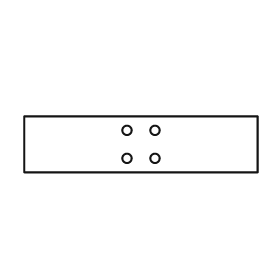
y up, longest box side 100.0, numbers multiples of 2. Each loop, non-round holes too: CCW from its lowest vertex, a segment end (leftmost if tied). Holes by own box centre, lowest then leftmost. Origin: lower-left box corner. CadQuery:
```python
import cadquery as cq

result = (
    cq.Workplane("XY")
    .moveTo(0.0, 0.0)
    .lineTo(100.0, 0.0)
    .lineTo(100.0, 24.0)
    .lineTo(0.0, 24.0)
    .close()
    .moveTo(44.0, 6.0)
    .circle(2.0)
    .moveTo(56.0, 6.0)
    .circle(2.0)
    .moveTo(44.0, 18.0)
    .circle(2.0)
    .moveTo(56.0, 18.0)
    .circle(2.0)
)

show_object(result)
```